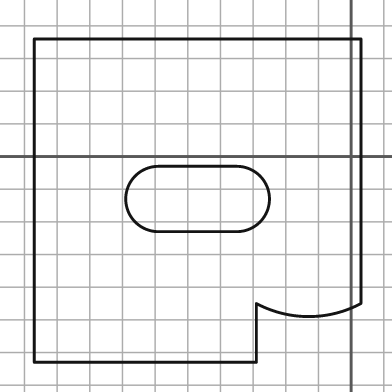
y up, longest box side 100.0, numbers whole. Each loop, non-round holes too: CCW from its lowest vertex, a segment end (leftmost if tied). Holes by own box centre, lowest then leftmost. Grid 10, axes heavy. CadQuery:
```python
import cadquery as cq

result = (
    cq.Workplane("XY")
    .moveTo(-97.0, -63.0)
    .lineTo(-29.0, -63.0)
    .lineTo(-29.0, -45.0)
    .threePointArc((-13.0, -49.0), (3.0, -45.0))
    .lineTo(3.0, 36.0)
    .lineTo(-97.0, 36.0)
    .close()
    .moveTo(-59.0, -23.0)
    .lineTo(-35.0, -23.0)
    .threePointArc((-25.0, -13.0), (-35.0, -3.0))
    .lineTo(-59.0, -3.0)
    .threePointArc((-69.0, -13.0), (-59.0, -23.0))
    .close()
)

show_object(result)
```